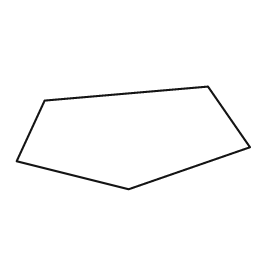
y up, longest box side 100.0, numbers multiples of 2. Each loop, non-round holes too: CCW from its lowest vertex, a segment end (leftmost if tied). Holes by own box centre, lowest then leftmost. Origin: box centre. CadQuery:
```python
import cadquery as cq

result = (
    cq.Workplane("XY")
    .moveTo(-2.0, -22.0)
    .lineTo(50.0, -4.0)
    .lineTo(32.0, 22.0)
    .lineTo(-38.0, 16.0)
    .lineTo(-50.0, -10.0)
    .close()
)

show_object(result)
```